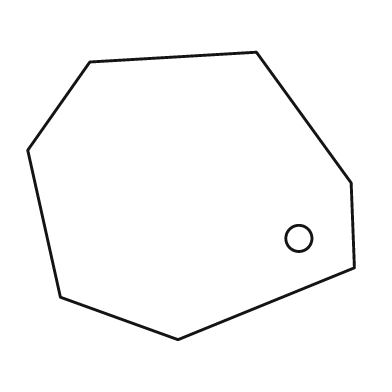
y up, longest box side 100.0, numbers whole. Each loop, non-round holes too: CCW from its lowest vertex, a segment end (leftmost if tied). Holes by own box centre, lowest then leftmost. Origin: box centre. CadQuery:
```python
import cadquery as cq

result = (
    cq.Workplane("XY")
    .moveTo(-4.0, -44.0)
    .lineTo(50.0, -22.0)
    .lineTo(49.0, 4.0)
    .lineTo(20.0, 44.0)
    .lineTo(-31.0, 41.0)
    .lineTo(-50.0, 14.0)
    .lineTo(-40.0, -31.0)
    .close()
    .moveTo(33.0, -13.0)
    .circle(4.0)
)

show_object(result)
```